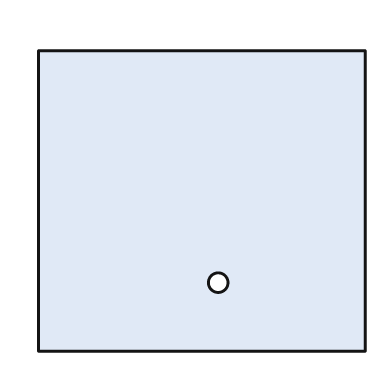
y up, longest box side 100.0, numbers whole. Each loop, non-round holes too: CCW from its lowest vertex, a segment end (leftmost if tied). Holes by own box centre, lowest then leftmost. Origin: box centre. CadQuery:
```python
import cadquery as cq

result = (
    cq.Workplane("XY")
    .moveTo(-50.0, -46.0)
    .lineTo(50.0, -46.0)
    .lineTo(50.0, 46.0)
    .lineTo(-50.0, 46.0)
    .close()
    .moveTo(5.0, -25.0)
    .circle(3.0)
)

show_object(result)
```